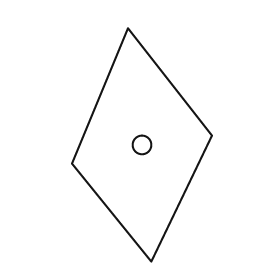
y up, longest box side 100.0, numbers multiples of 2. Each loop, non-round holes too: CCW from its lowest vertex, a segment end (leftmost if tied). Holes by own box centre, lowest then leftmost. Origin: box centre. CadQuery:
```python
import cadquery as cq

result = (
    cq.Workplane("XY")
    .moveTo(4.0, -50.0)
    .lineTo(30.0, 4.0)
    .lineTo(-6.0, 50.0)
    .lineTo(-30.0, -8.0)
    .close()
    .moveTo(0.0, 0.0)
    .circle(4.0)
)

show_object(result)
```